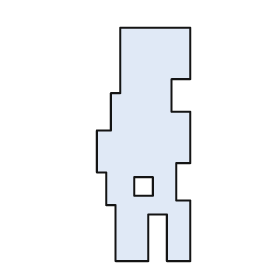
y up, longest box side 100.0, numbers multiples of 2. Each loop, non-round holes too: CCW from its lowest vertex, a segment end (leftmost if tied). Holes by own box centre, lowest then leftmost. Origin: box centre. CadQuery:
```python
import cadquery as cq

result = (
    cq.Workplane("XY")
    .moveTo(-12.0, -50.0)
    .lineTo(2.0, -50.0)
    .lineTo(2.0, -30.0)
    .lineTo(10.0, -30.0)
    .lineTo(10.0, -50.0)
    .lineTo(20.0, -50.0)
    .lineTo(20.0, -24.0)
    .lineTo(14.0, -24.0)
    .lineTo(14.0, -8.0)
    .lineTo(20.0, -8.0)
    .lineTo(20.0, 14.0)
    .lineTo(12.0, 14.0)
    .lineTo(12.0, 28.0)
    .lineTo(20.0, 28.0)
    .lineTo(20.0, 50.0)
    .lineTo(-10.0, 50.0)
    .lineTo(-10.0, 22.0)
    .lineTo(-14.0, 22.0)
    .lineTo(-14.0, 6.0)
    .lineTo(-20.0, 6.0)
    .lineTo(-20.0, -12.0)
    .lineTo(-16.0, -12.0)
    .lineTo(-16.0, -26.0)
    .lineTo(-12.0, -26.0)
    .close()
    .moveTo(-4.0, -22.0)
    .lineTo(4.0, -22.0)
    .lineTo(4.0, -14.0)
    .lineTo(-4.0, -14.0)
    .close()
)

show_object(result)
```